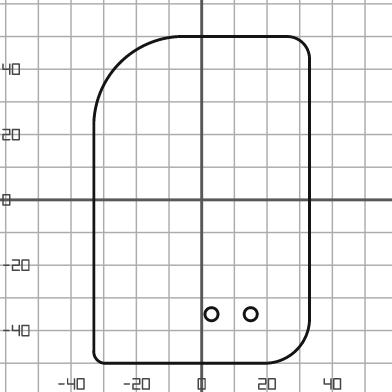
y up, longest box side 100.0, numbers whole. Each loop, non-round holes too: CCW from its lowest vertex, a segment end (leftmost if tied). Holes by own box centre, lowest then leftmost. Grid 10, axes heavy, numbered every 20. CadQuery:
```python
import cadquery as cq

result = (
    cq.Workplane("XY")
    .moveTo(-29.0, -50.0)
    .lineTo(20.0, -50.0)
    .threePointArc((29.0, -46.0), (33.0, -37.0))
    .lineTo(33.0, 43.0)
    .threePointArc((31.0, 48.0), (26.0, 50.0))
    .lineTo(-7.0, 50.0)
    .threePointArc((-25.0, 42.0), (-33.0, 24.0))
    .lineTo(-33.0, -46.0)
    .threePointArc((-32.0, -49.0), (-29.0, -50.0))
    .close()
    .moveTo(3.0, -35.0)
    .circle(2.0)
    .moveTo(15.0, -35.0)
    .circle(2.0)
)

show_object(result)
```